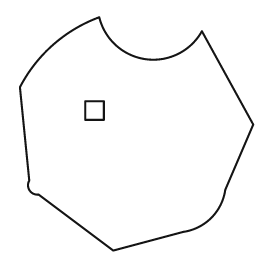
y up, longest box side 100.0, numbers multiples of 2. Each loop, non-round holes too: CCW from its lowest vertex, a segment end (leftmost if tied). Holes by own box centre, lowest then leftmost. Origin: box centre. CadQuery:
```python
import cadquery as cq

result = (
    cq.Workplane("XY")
    .moveTo(-10.0, -50.0)
    .lineTo(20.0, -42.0)
    .threePointArc((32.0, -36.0), (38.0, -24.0))
    .lineTo(50.0, 4.0)
    .lineTo(28.0, 44.0)
    .threePointArc((4.0, 32.0), (-16.0, 50.0))
    .threePointArc((-36.0, 38.0), (-50.0, 20.0))
    .lineTo(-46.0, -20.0)
    .threePointArc((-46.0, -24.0), (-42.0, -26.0))
    .close()
    .moveTo(-22.0, 6.0)
    .lineTo(-14.0, 6.0)
    .lineTo(-14.0, 14.0)
    .lineTo(-22.0, 14.0)
    .close()
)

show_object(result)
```